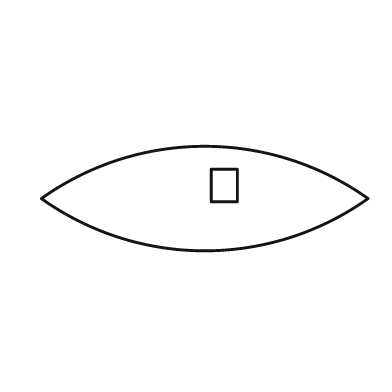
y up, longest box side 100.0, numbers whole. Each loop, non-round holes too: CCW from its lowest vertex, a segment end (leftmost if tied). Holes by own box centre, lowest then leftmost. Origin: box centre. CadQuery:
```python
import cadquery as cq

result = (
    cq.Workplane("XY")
    .moveTo(-50.0, 0.0)
    .threePointArc((0.0, -16.0), (50.0, 0.0))
    .threePointArc((0.0, 16.0), (-50.0, 0.0))
    .close()
    .moveTo(2.0, -1.0)
    .lineTo(10.0, -1.0)
    .lineTo(10.0, 9.0)
    .lineTo(2.0, 9.0)
    .close()
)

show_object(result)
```